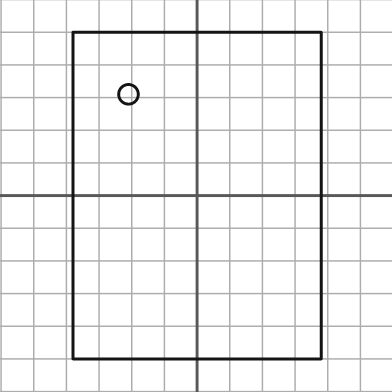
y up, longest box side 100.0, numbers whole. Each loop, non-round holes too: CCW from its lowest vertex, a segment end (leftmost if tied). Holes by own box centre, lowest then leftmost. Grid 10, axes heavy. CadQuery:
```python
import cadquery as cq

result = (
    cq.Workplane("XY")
    .moveTo(-38.0, -50.0)
    .lineTo(38.0, -50.0)
    .lineTo(38.0, 50.0)
    .lineTo(-38.0, 50.0)
    .close()
    .moveTo(-21.0, 31.0)
    .circle(3.0)
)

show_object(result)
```